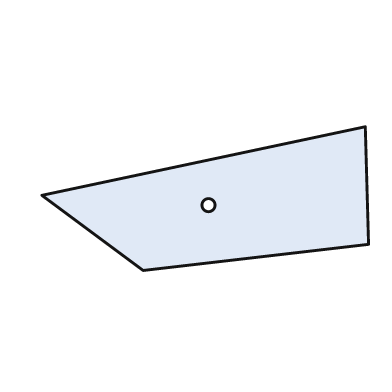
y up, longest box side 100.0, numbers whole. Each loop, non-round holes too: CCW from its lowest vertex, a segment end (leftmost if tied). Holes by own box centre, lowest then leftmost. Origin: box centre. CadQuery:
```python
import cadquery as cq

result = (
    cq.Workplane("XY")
    .moveTo(-19.0, -22.0)
    .lineTo(50.0, -14.0)
    .lineTo(49.0, 22.0)
    .lineTo(-50.0, 1.0)
    .close()
    .moveTo(1.0, -2.0)
    .circle(2.0)
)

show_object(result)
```